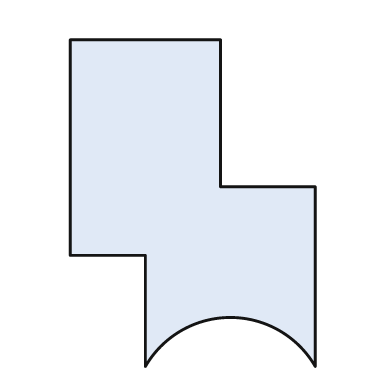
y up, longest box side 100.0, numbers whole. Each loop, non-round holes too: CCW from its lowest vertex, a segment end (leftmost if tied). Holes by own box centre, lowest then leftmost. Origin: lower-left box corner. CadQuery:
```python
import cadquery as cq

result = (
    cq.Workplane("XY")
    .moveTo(23.0, 0.0)
    .threePointArc((49.0, 15.0), (75.0, 0.0))
    .lineTo(75.0, 55.0)
    .lineTo(46.0, 55.0)
    .lineTo(46.0, 100.0)
    .lineTo(0.0, 100.0)
    .lineTo(0.0, 34.0)
    .lineTo(23.0, 34.0)
    .close()
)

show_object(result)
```